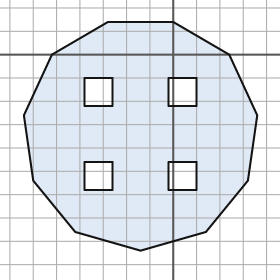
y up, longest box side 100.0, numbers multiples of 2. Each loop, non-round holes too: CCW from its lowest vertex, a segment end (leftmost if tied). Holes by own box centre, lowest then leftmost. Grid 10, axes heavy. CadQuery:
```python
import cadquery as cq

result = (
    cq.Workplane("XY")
    .moveTo(-14.0, -84.0)
    .lineTo(14.0, -76.0)
    .lineTo(32.0, -54.0)
    .lineTo(36.0, -26.0)
    .lineTo(24.0, 0.0)
    .lineTo(0.0, 14.0)
    .lineTo(-28.0, 14.0)
    .lineTo(-52.0, 0.0)
    .lineTo(-64.0, -26.0)
    .lineTo(-60.0, -54.0)
    .lineTo(-42.0, -76.0)
    .close()
    .moveTo(-38.0, -58.0)
    .lineTo(-26.0, -58.0)
    .lineTo(-26.0, -46.0)
    .lineTo(-38.0, -46.0)
    .close()
    .moveTo(-2.0, -58.0)
    .lineTo(10.0, -58.0)
    .lineTo(10.0, -46.0)
    .lineTo(-2.0, -46.0)
    .close()
    .moveTo(-38.0, -22.0)
    .lineTo(-26.0, -22.0)
    .lineTo(-26.0, -10.0)
    .lineTo(-38.0, -10.0)
    .close()
    .moveTo(-2.0, -22.0)
    .lineTo(10.0, -22.0)
    .lineTo(10.0, -10.0)
    .lineTo(-2.0, -10.0)
    .close()
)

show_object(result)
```